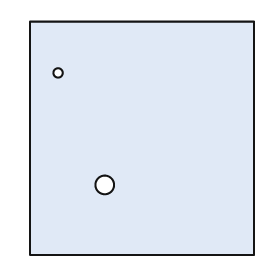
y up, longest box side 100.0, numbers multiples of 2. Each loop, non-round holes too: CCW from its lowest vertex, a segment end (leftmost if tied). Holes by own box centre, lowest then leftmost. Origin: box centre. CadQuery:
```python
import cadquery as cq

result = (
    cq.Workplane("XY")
    .moveTo(-48.0, -50.0)
    .lineTo(48.0, -50.0)
    .lineTo(48.0, 50.0)
    .lineTo(-48.0, 50.0)
    .close()
    .moveTo(-16.0, -20.0)
    .circle(4.0)
    .moveTo(-36.0, 28.0)
    .circle(2.0)
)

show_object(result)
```